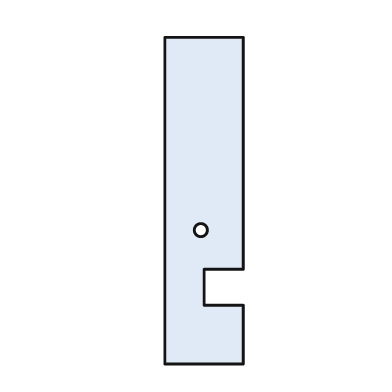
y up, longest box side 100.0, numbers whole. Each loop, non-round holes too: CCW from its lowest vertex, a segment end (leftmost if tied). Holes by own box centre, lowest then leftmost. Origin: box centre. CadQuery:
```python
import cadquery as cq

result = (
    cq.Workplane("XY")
    .moveTo(-12.0, -50.0)
    .lineTo(12.0, -50.0)
    .lineTo(12.0, -32.0)
    .lineTo(0.0, -32.0)
    .lineTo(0.0, -21.0)
    .lineTo(12.0, -21.0)
    .lineTo(12.0, 50.0)
    .lineTo(-12.0, 50.0)
    .close()
    .moveTo(-1.0, -9.0)
    .circle(2.0)
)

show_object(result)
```